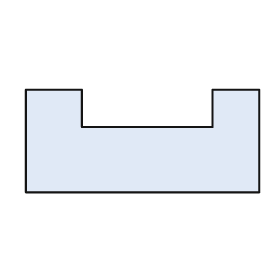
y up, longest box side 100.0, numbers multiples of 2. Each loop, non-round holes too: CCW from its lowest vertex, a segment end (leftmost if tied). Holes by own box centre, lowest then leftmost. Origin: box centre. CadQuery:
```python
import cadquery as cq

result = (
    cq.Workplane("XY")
    .moveTo(-50.0, -22.0)
    .lineTo(50.0, -22.0)
    .lineTo(50.0, 22.0)
    .lineTo(30.0, 22.0)
    .lineTo(30.0, 6.0)
    .lineTo(-26.0, 6.0)
    .lineTo(-26.0, 22.0)
    .lineTo(-50.0, 22.0)
    .close()
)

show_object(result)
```